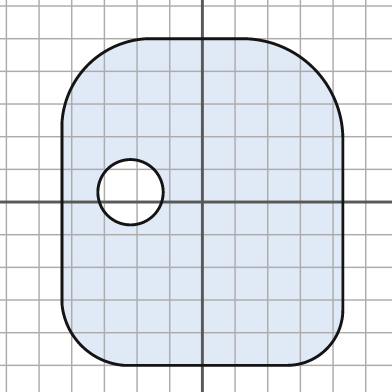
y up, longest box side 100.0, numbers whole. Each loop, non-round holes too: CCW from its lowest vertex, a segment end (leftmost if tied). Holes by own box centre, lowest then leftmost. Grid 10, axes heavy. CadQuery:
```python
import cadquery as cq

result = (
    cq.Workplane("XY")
    .moveTo(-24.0, -50.0)
    .lineTo(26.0, -50.0)
    .threePointArc((38.0, -45.0), (43.0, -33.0))
    .lineTo(43.0, 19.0)
    .threePointArc((34.0, 41.0), (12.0, 50.0))
    .lineTo(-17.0, 50.0)
    .threePointArc((-35.0, 42.0), (-43.0, 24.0))
    .lineTo(-43.0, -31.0)
    .threePointArc((-37.0, -44.0), (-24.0, -50.0))
    .close()
    .moveTo(-22.0, 3.0)
    .circle(10.0)
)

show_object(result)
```